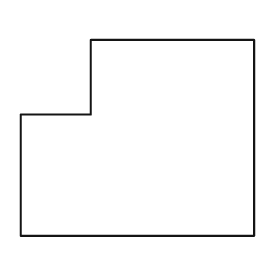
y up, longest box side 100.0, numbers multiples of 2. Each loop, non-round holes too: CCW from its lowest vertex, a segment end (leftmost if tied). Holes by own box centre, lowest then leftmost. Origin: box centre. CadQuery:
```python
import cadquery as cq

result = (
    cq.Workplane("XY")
    .moveTo(-50.0, -42.0)
    .lineTo(50.0, -42.0)
    .lineTo(50.0, 42.0)
    .lineTo(-20.0, 42.0)
    .lineTo(-20.0, 10.0)
    .lineTo(-50.0, 10.0)
    .close()
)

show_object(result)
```